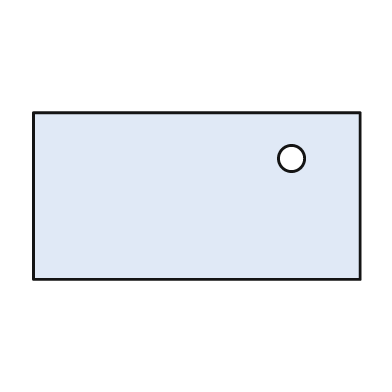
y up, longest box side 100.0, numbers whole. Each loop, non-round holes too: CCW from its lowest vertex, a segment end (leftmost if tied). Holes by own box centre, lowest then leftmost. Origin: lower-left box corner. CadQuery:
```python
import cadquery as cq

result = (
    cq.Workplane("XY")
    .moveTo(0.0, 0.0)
    .lineTo(100.0, 0.0)
    .lineTo(100.0, 51.0)
    .lineTo(0.0, 51.0)
    .close()
    .moveTo(79.0, 37.0)
    .circle(4.0)
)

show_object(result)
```